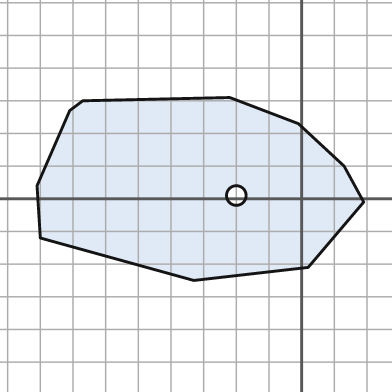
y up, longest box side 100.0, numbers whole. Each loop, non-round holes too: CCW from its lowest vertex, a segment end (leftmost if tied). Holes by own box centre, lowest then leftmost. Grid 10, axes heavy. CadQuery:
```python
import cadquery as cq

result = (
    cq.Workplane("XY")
    .moveTo(-33.0, -25.0)
    .lineTo(2.0, -21.0)
    .lineTo(19.0, -1.0)
    .lineTo(13.0, 10.0)
    .lineTo(-1.0, 23.0)
    .lineTo(-22.0, 31.0)
    .lineTo(-67.0, 30.0)
    .lineTo(-71.0, 27.0)
    .lineTo(-81.0, 4.0)
    .lineTo(-80.0, -12.0)
    .close()
    .moveTo(-20.0, 1.0)
    .circle(3.0)
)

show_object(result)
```